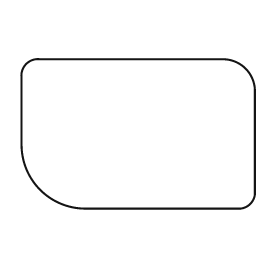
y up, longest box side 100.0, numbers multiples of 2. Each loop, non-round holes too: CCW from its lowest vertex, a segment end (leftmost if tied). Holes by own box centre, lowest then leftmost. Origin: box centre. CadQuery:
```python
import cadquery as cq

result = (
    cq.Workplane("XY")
    .moveTo(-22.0, -32.0)
    .lineTo(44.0, -32.0)
    .threePointArc((48.0, -30.0), (50.0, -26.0))
    .lineTo(50.0, 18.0)
    .threePointArc((46.0, 28.0), (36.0, 32.0))
    .lineTo(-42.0, 32.0)
    .threePointArc((-48.0, 30.0), (-50.0, 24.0))
    .lineTo(-50.0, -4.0)
    .threePointArc((-42.0, -24.0), (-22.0, -32.0))
    .close()
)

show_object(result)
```